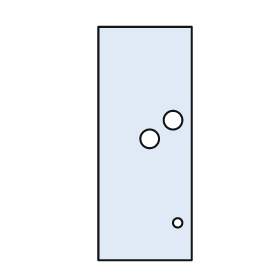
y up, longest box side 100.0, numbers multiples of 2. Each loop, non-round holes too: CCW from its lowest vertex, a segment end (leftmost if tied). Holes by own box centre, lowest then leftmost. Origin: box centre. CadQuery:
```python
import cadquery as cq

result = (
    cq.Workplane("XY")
    .moveTo(-20.0, -50.0)
    .lineTo(20.0, -50.0)
    .lineTo(20.0, 50.0)
    .lineTo(-20.0, 50.0)
    .close()
    .moveTo(14.0, -34.0)
    .circle(2.0)
    .moveTo(2.0, 2.0)
    .circle(4.0)
    .moveTo(12.0, 10.0)
    .circle(4.0)
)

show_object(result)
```